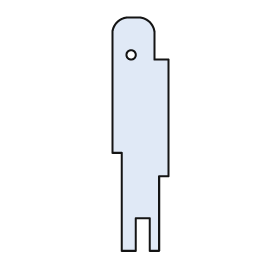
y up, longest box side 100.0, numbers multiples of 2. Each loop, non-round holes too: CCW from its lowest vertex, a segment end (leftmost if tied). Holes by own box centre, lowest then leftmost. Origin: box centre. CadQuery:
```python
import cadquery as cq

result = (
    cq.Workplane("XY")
    .moveTo(-8.0, -50.0)
    .lineTo(-2.0, -50.0)
    .lineTo(-2.0, -36.0)
    .lineTo(4.0, -36.0)
    .lineTo(4.0, -50.0)
    .lineTo(8.0, -50.0)
    .lineTo(8.0, -18.0)
    .lineTo(12.0, -18.0)
    .lineTo(12.0, 32.0)
    .lineTo(6.0, 32.0)
    .lineTo(6.0, 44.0)
    .threePointArc((4.0, 48.0), (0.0, 50.0))
    .lineTo(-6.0, 50.0)
    .threePointArc((-10.0, 48.0), (-12.0, 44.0))
    .lineTo(-12.0, -8.0)
    .lineTo(-8.0, -8.0)
    .close()
    .moveTo(-4.0, 34.0)
    .circle(2.0)
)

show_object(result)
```